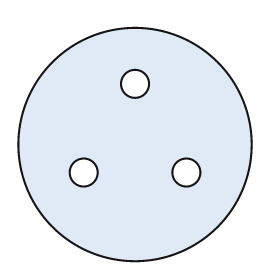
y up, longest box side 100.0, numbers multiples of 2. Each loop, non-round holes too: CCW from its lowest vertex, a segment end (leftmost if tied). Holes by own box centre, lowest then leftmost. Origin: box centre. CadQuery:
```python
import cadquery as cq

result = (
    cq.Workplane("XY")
    .moveTo(0.0, 0.0)
    .circle(50.0)
    .moveTo(-22.0, -12.0)
    .circle(6.0)
    .moveTo(22.0, -12.0)
    .circle(6.0)
    .moveTo(0.0, 26.0)
    .circle(6.0)
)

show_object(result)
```